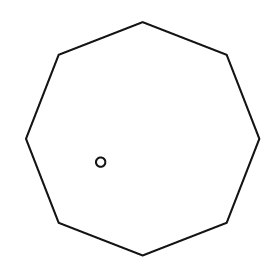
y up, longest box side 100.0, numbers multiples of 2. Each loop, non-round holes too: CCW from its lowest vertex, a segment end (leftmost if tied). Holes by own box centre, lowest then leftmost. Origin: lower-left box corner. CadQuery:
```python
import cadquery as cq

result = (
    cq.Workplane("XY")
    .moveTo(50.0, 0.0)
    .lineTo(86.0, 14.0)
    .lineTo(100.0, 50.0)
    .lineTo(86.0, 86.0)
    .lineTo(50.0, 100.0)
    .lineTo(14.0, 86.0)
    .lineTo(0.0, 50.0)
    .lineTo(14.0, 14.0)
    .close()
    .moveTo(32.0, 40.0)
    .circle(2.0)
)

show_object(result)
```